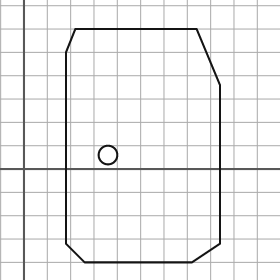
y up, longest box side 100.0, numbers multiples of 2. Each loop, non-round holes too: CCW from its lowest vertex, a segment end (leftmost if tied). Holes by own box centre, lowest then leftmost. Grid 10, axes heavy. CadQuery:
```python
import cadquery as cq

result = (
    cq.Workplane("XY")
    .moveTo(26.0, -40.0)
    .lineTo(72.0, -40.0)
    .lineTo(84.0, -32.0)
    .lineTo(84.0, 36.0)
    .lineTo(74.0, 60.0)
    .lineTo(22.0, 60.0)
    .lineTo(18.0, 50.0)
    .lineTo(18.0, -32.0)
    .close()
    .moveTo(36.0, 6.0)
    .circle(4.0)
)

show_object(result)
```